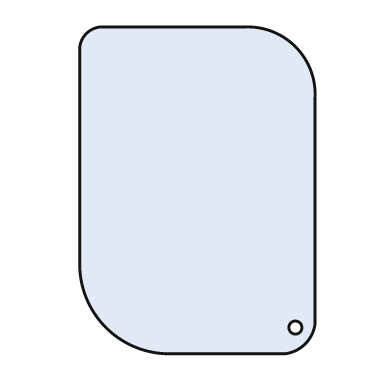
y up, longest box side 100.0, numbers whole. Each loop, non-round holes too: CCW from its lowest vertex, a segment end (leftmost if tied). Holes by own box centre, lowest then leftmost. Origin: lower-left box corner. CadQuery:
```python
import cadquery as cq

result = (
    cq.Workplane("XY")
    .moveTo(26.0, 0.0)
    .lineTo(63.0, 0.0)
    .threePointArc((69.0, 3.0), (72.0, 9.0))
    .lineTo(72.0, 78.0)
    .threePointArc((66.0, 94.0), (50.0, 100.0))
    .lineTo(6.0, 100.0)
    .threePointArc((2.0, 98.0), (0.0, 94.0))
    .lineTo(0.0, 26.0)
    .threePointArc((8.0, 8.0), (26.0, 0.0))
    .close()
    .moveTo(66.0, 8.0)
    .circle(2.0)
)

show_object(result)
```